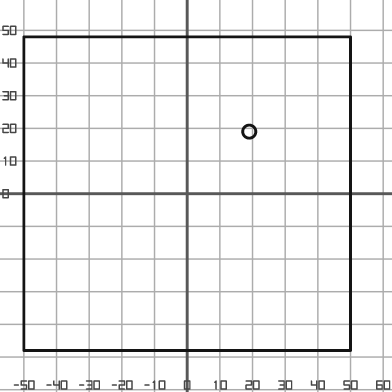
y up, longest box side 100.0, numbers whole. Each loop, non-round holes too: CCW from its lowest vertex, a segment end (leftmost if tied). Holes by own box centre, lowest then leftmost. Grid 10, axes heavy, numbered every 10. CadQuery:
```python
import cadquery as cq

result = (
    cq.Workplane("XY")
    .moveTo(-50.0, -48.0)
    .lineTo(50.0, -48.0)
    .lineTo(50.0, 48.0)
    .lineTo(-50.0, 48.0)
    .close()
    .moveTo(19.0, 19.0)
    .circle(2.0)
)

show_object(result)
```